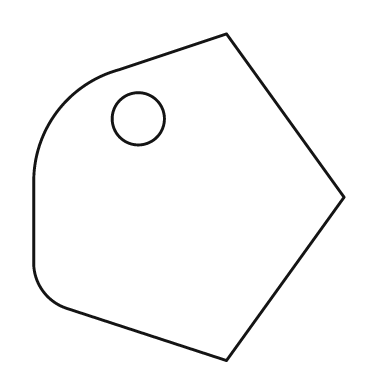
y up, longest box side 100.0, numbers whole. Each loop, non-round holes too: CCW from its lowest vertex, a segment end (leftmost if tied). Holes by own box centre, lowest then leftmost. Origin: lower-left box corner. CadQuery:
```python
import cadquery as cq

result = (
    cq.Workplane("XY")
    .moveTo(59.0, 0.0)
    .lineTo(95.0, 50.0)
    .lineTo(59.0, 100.0)
    .lineTo(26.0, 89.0)
    .threePointArc((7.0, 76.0), (0.0, 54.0))
    .lineTo(0.0, 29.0)
    .threePointArc((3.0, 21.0), (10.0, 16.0))
    .close()
    .moveTo(32.0, 74.0)
    .circle(8.0)
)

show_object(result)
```